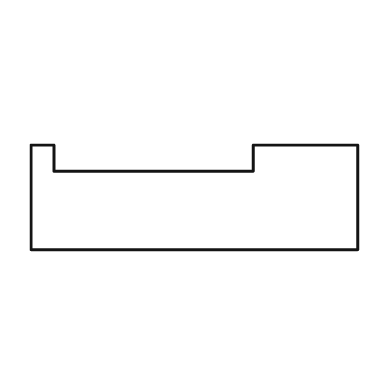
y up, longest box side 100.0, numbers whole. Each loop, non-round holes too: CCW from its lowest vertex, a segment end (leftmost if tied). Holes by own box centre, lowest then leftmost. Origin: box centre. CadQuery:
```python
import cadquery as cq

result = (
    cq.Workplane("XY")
    .moveTo(-50.0, -16.0)
    .lineTo(50.0, -16.0)
    .lineTo(50.0, 16.0)
    .lineTo(18.0, 16.0)
    .lineTo(18.0, 8.0)
    .lineTo(-43.0, 8.0)
    .lineTo(-43.0, 16.0)
    .lineTo(-50.0, 16.0)
    .close()
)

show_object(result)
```